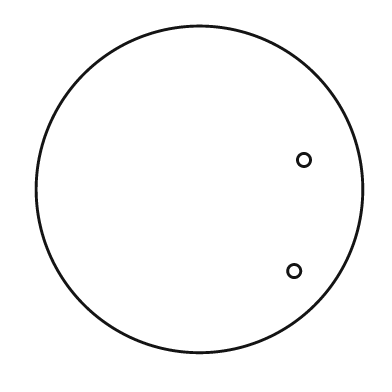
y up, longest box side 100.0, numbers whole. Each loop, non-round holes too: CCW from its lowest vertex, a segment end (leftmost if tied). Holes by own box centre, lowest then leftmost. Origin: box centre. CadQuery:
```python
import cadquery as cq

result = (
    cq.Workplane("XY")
    .moveTo(0.0, 0.0)
    .circle(50.0)
    .moveTo(29.0, -25.0)
    .circle(2.0)
    .moveTo(32.0, 9.0)
    .circle(2.0)
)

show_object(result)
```